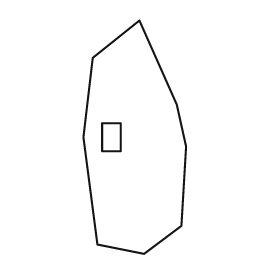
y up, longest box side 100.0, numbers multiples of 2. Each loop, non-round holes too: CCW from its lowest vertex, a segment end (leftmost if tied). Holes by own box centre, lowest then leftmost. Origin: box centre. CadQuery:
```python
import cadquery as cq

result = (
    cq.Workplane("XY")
    .moveTo(4.0, -50.0)
    .lineTo(20.0, -38.0)
    .lineTo(22.0, -4.0)
    .lineTo(18.0, 14.0)
    .lineTo(2.0, 50.0)
    .lineTo(-18.0, 34.0)
    .lineTo(-22.0, 0.0)
    .lineTo(-16.0, -46.0)
    .close()
    .moveTo(-14.0, -6.0)
    .lineTo(-6.0, -6.0)
    .lineTo(-6.0, 6.0)
    .lineTo(-14.0, 6.0)
    .close()
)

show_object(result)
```